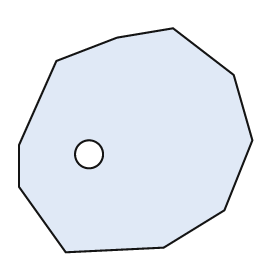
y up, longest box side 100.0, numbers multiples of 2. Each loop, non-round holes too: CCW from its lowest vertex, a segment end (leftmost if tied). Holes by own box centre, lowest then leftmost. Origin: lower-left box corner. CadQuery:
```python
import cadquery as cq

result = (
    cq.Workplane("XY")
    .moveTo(20.0, 0.0)
    .lineTo(62.0, 2.0)
    .lineTo(88.0, 18.0)
    .lineTo(100.0, 48.0)
    .lineTo(92.0, 76.0)
    .lineTo(66.0, 96.0)
    .lineTo(42.0, 92.0)
    .lineTo(16.0, 82.0)
    .lineTo(0.0, 46.0)
    .lineTo(0.0, 28.0)
    .close()
    .moveTo(30.0, 42.0)
    .circle(6.0)
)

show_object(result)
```